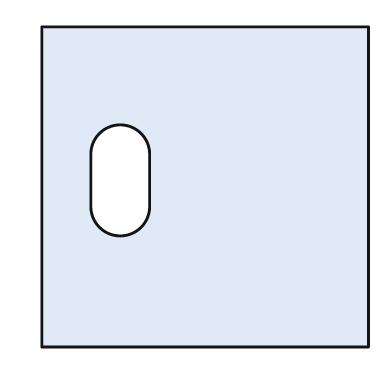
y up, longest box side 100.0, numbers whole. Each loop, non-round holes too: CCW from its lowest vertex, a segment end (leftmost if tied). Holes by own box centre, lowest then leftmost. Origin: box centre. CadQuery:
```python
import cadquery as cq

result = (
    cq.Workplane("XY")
    .moveTo(-50.0, -49.0)
    .lineTo(50.0, -49.0)
    .lineTo(50.0, 49.0)
    .lineTo(-50.0, 49.0)
    .close()
    .moveTo(-35.0, -6.0)
    .threePointArc((-26.0, -15.0), (-17.0, -6.0))
    .lineTo(-17.0, 10.0)
    .threePointArc((-26.0, 19.0), (-35.0, 10.0))
    .close()
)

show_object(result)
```